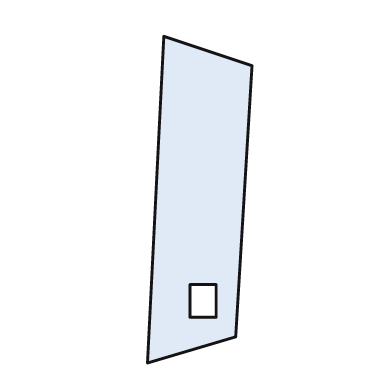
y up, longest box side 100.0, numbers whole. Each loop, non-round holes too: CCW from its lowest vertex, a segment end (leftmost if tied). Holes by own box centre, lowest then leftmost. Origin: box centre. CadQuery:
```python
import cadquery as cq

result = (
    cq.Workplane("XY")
    .moveTo(-16.0, -50.0)
    .lineTo(11.0, -42.0)
    .lineTo(16.0, 41.0)
    .lineTo(-11.0, 50.0)
    .close()
    .moveTo(-3.0, -36.0)
    .lineTo(5.0, -36.0)
    .lineTo(5.0, -26.0)
    .lineTo(-3.0, -26.0)
    .close()
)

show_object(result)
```